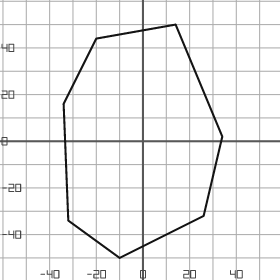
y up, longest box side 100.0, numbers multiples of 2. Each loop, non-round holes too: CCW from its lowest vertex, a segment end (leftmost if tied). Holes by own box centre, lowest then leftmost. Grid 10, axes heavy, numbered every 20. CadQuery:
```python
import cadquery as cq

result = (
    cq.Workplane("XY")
    .moveTo(-10.0, -50.0)
    .lineTo(26.0, -32.0)
    .lineTo(34.0, 2.0)
    .lineTo(14.0, 50.0)
    .lineTo(-20.0, 44.0)
    .lineTo(-34.0, 16.0)
    .lineTo(-32.0, -34.0)
    .close()
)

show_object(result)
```